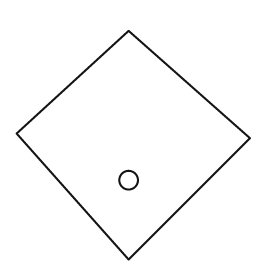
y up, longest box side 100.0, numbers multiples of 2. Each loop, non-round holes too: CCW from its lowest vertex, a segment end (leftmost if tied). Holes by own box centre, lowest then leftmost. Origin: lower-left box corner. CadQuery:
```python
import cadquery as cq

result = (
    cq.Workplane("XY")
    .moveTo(48.0, 0.0)
    .lineTo(100.0, 52.0)
    .lineTo(48.0, 98.0)
    .lineTo(0.0, 54.0)
    .close()
    .moveTo(48.0, 34.0)
    .circle(4.0)
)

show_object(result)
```